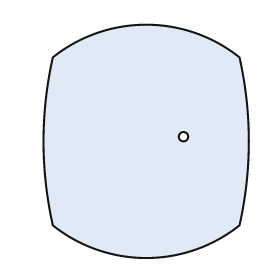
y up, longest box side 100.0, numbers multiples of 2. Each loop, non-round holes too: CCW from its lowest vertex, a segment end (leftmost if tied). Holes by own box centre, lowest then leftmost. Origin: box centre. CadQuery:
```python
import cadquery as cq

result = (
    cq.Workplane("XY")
    .moveTo(-40.0, -36.0)
    .threePointArc((0.0, -50.0), (40.0, -36.0))
    .threePointArc((44.0, 0.0), (40.0, 36.0))
    .threePointArc((0.0, 50.0), (-40.0, 36.0))
    .threePointArc((-44.0, 0.0), (-40.0, -36.0))
    .close()
    .moveTo(16.0, 2.0)
    .circle(2.0)
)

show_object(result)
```